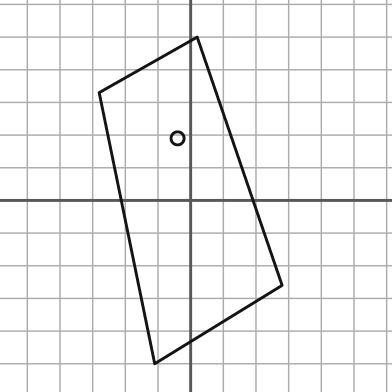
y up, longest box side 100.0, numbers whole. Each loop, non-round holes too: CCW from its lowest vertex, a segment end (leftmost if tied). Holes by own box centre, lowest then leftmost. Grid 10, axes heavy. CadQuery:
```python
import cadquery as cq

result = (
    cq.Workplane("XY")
    .moveTo(-11.0, -50.0)
    .lineTo(28.0, -26.0)
    .lineTo(2.0, 50.0)
    .lineTo(-28.0, 33.0)
    .close()
    .moveTo(-4.0, 19.0)
    .circle(2.0)
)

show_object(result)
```